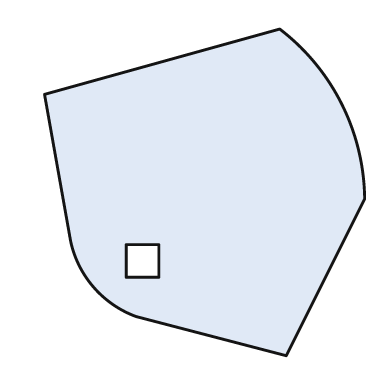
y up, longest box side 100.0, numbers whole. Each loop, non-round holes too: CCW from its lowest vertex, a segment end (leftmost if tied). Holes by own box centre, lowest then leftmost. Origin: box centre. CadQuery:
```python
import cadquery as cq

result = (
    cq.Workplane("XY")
    .moveTo(25.0, -50.0)
    .lineTo(49.0, -2.0)
    .threePointArc((42.0, 27.0), (23.0, 50.0))
    .lineTo(-49.0, 30.0)
    .lineTo(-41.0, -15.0)
    .threePointArc((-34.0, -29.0), (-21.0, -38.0))
    .close()
    .moveTo(-24.0, -26.0)
    .lineTo(-14.0, -26.0)
    .lineTo(-14.0, -16.0)
    .lineTo(-24.0, -16.0)
    .close()
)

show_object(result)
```